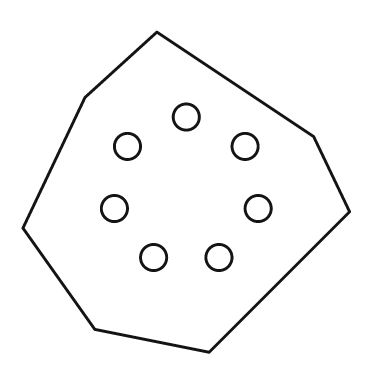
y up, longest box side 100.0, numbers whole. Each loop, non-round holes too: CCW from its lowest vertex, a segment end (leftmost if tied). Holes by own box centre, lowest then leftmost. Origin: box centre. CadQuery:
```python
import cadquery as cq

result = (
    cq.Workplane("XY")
    .moveTo(7.0, -49.0)
    .lineTo(50.0, -6.0)
    .lineTo(39.0, 17.0)
    .lineTo(-9.0, 49.0)
    .lineTo(-31.0, 29.0)
    .lineTo(-50.0, -11.0)
    .lineTo(-28.0, -42.0)
    .close()
    .moveTo(-10.0, -20.0)
    .circle(4.0)
    .moveTo(10.0, -20.0)
    .circle(4.0)
    .moveTo(-22.0, -5.0)
    .circle(4.0)
    .moveTo(22.0, -5.0)
    .circle(4.0)
    .moveTo(-18.0, 14.0)
    .circle(4.0)
    .moveTo(18.0, 14.0)
    .circle(4.0)
    .moveTo(0.0, 23.0)
    .circle(4.0)
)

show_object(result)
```